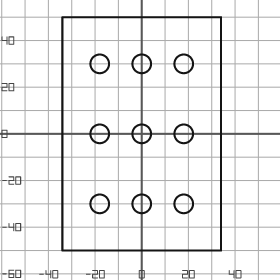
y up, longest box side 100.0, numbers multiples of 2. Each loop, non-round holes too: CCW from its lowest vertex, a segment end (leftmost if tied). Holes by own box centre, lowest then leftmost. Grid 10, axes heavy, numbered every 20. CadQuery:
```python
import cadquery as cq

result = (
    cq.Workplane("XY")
    .moveTo(-34.0, -50.0)
    .lineTo(34.0, -50.0)
    .lineTo(34.0, 50.0)
    .lineTo(-34.0, 50.0)
    .close()
    .moveTo(-18.0, -30.0)
    .circle(4.0)
    .moveTo(0.0, -30.0)
    .circle(4.0)
    .moveTo(18.0, -30.0)
    .circle(4.0)
    .moveTo(-18.0, 0.0)
    .circle(4.0)
    .moveTo(0.0, 0.0)
    .circle(4.0)
    .moveTo(18.0, 0.0)
    .circle(4.0)
    .moveTo(-18.0, 30.0)
    .circle(4.0)
    .moveTo(0.0, 30.0)
    .circle(4.0)
    .moveTo(18.0, 30.0)
    .circle(4.0)
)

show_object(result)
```